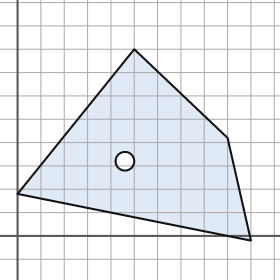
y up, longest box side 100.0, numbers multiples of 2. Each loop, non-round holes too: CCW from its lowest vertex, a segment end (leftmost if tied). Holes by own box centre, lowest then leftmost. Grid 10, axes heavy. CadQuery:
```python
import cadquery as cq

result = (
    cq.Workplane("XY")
    .moveTo(100.0, -2.0)
    .lineTo(90.0, 42.0)
    .lineTo(50.0, 80.0)
    .lineTo(0.0, 18.0)
    .close()
    .moveTo(46.0, 32.0)
    .circle(4.0)
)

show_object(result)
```